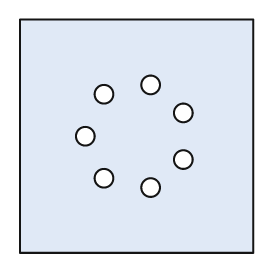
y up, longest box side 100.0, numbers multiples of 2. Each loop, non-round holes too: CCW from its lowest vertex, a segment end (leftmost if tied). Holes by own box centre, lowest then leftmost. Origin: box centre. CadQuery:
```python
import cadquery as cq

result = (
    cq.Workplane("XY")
    .moveTo(-50.0, -50.0)
    .lineTo(50.0, -50.0)
    .lineTo(50.0, 50.0)
    .lineTo(-50.0, 50.0)
    .close()
    .moveTo(6.0, -22.0)
    .circle(4.0)
    .moveTo(-14.0, -18.0)
    .circle(4.0)
    .moveTo(20.0, -10.0)
    .circle(4.0)
    .moveTo(-22.0, 0.0)
    .circle(4.0)
    .moveTo(20.0, 10.0)
    .circle(4.0)
    .moveTo(-14.0, 18.0)
    .circle(4.0)
    .moveTo(6.0, 22.0)
    .circle(4.0)
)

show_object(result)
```